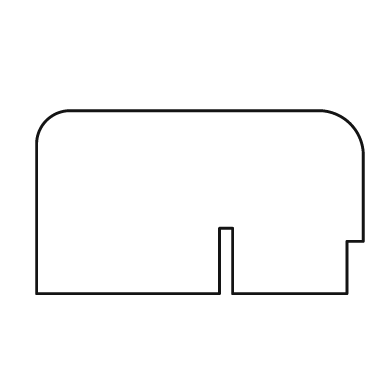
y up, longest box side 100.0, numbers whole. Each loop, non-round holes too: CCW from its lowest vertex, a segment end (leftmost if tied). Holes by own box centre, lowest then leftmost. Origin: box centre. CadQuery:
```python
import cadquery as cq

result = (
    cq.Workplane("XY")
    .moveTo(-50.0, -28.0)
    .lineTo(6.0, -28.0)
    .lineTo(6.0, -8.0)
    .lineTo(10.0, -8.0)
    .lineTo(10.0, -28.0)
    .lineTo(45.0, -28.0)
    .lineTo(45.0, -12.0)
    .lineTo(50.0, -12.0)
    .lineTo(50.0, 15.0)
    .threePointArc((46.0, 24.0), (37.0, 28.0))
    .lineTo(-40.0, 28.0)
    .threePointArc((-47.0, 25.0), (-50.0, 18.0))
    .close()
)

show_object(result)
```